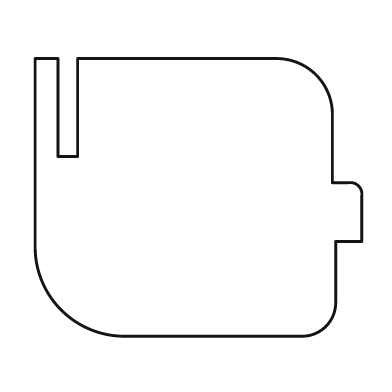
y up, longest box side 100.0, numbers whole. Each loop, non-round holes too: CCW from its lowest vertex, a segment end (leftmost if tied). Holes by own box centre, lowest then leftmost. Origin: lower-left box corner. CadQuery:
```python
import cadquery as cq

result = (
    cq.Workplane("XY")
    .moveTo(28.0, 0.0)
    .lineTo(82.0, 0.0)
    .threePointArc((89.0, 3.0), (92.0, 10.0))
    .lineTo(92.0, 29.0)
    .lineTo(100.0, 29.0)
    .lineTo(100.0, 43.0)
    .threePointArc((99.0, 46.0), (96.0, 47.0))
    .lineTo(91.0, 47.0)
    .lineTo(91.0, 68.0)
    .threePointArc((86.0, 80.0), (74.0, 85.0))
    .lineTo(13.0, 85.0)
    .lineTo(13.0, 55.0)
    .lineTo(7.0, 55.0)
    .lineTo(7.0, 85.0)
    .lineTo(0.0, 85.0)
    .lineTo(0.0, 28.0)
    .threePointArc((8.0, 8.0), (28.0, 0.0))
    .close()
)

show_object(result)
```